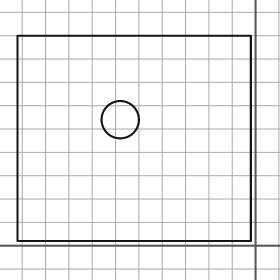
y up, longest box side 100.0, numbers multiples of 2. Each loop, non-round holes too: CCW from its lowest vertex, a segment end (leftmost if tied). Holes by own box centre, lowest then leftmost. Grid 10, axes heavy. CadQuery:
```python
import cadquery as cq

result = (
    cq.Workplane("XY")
    .moveTo(-102.0, 2.0)
    .lineTo(-2.0, 2.0)
    .lineTo(-2.0, 90.0)
    .lineTo(-102.0, 90.0)
    .close()
    .moveTo(-58.0, 54.0)
    .circle(8.0)
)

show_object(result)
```